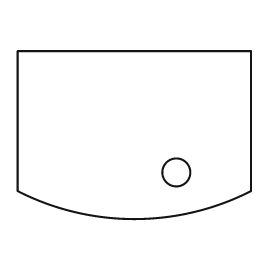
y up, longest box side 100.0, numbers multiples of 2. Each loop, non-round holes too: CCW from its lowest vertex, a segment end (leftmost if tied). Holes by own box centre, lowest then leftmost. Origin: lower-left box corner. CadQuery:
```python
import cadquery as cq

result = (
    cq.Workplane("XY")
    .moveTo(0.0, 12.0)
    .threePointArc((50.0, 0.0), (100.0, 12.0))
    .lineTo(100.0, 72.0)
    .lineTo(0.0, 72.0)
    .close()
    .moveTo(68.0, 20.0)
    .circle(6.0)
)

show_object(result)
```